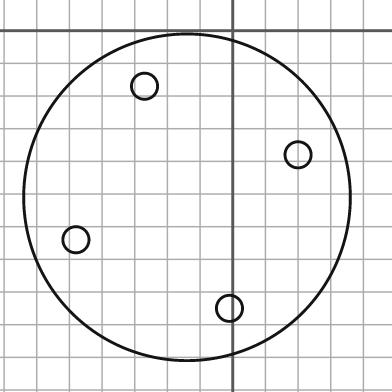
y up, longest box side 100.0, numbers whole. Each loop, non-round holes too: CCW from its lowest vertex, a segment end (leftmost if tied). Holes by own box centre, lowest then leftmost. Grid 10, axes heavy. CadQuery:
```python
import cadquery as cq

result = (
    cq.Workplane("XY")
    .moveTo(-14.0, -51.0)
    .circle(50.0)
    .moveTo(-1.0, -85.0)
    .circle(4.0)
    .moveTo(-48.0, -64.0)
    .circle(4.0)
    .moveTo(20.0, -38.0)
    .circle(4.0)
    .moveTo(-27.0, -17.0)
    .circle(4.0)
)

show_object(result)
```